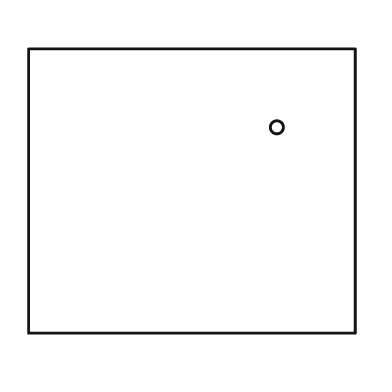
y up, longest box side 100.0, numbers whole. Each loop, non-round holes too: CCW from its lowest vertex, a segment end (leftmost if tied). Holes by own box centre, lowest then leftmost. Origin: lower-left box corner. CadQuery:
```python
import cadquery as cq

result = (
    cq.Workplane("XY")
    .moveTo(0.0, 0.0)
    .lineTo(100.0, 0.0)
    .lineTo(100.0, 87.0)
    .lineTo(0.0, 87.0)
    .close()
    .moveTo(76.0, 63.0)
    .circle(2.0)
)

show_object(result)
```